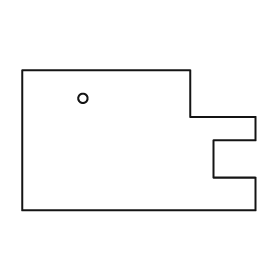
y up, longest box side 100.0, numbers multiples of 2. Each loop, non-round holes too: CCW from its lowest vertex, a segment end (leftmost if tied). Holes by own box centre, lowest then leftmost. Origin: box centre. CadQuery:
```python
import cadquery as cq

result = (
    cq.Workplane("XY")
    .moveTo(-50.0, -30.0)
    .lineTo(50.0, -30.0)
    .lineTo(50.0, -16.0)
    .lineTo(32.0, -16.0)
    .lineTo(32.0, 0.0)
    .lineTo(50.0, 0.0)
    .lineTo(50.0, 10.0)
    .lineTo(22.0, 10.0)
    .lineTo(22.0, 30.0)
    .lineTo(-50.0, 30.0)
    .close()
    .moveTo(-24.0, 18.0)
    .circle(2.0)
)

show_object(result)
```